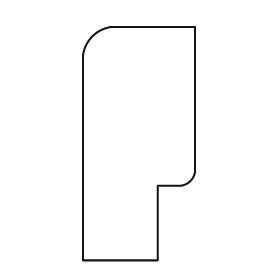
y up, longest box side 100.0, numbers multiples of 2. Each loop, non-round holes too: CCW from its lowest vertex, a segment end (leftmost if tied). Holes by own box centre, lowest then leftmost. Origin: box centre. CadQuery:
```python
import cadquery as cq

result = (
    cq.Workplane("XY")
    .moveTo(-24.0, -50.0)
    .lineTo(8.0, -50.0)
    .lineTo(8.0, -18.0)
    .lineTo(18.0, -18.0)
    .threePointArc((22.0, -16.0), (24.0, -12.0))
    .lineTo(24.0, 50.0)
    .lineTo(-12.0, 50.0)
    .threePointArc((-20.0, 46.0), (-24.0, 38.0))
    .close()
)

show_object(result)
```